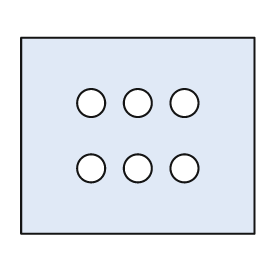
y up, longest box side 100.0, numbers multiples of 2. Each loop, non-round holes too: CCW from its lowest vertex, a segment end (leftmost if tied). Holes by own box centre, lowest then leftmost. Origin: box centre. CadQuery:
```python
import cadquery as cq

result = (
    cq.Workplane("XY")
    .moveTo(-50.0, -42.0)
    .lineTo(50.0, -42.0)
    .lineTo(50.0, 42.0)
    .lineTo(-50.0, 42.0)
    .close()
    .moveTo(-20.0, -14.0)
    .circle(6.0)
    .moveTo(0.0, -14.0)
    .circle(6.0)
    .moveTo(20.0, -14.0)
    .circle(6.0)
    .moveTo(-20.0, 14.0)
    .circle(6.0)
    .moveTo(0.0, 14.0)
    .circle(6.0)
    .moveTo(20.0, 14.0)
    .circle(6.0)
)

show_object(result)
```